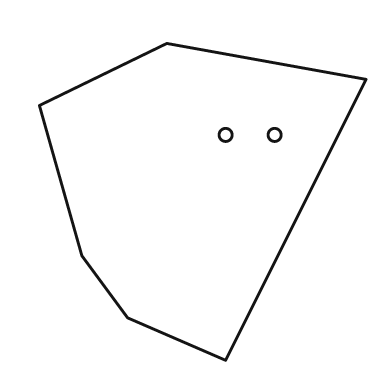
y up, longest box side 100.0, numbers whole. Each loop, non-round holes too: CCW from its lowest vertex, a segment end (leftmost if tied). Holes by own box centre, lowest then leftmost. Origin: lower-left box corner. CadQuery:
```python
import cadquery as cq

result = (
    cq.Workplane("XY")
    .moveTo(57.0, 0.0)
    .lineTo(100.0, 86.0)
    .lineTo(39.0, 97.0)
    .lineTo(0.0, 78.0)
    .lineTo(13.0, 32.0)
    .lineTo(27.0, 13.0)
    .close()
    .moveTo(57.0, 69.0)
    .circle(2.0)
    .moveTo(72.0, 69.0)
    .circle(2.0)
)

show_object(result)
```